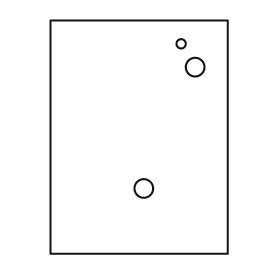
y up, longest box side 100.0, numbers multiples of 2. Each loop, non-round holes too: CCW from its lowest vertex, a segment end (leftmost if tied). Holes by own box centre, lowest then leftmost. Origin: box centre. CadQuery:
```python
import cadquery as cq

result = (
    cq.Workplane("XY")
    .moveTo(-38.0, -50.0)
    .lineTo(38.0, -50.0)
    .lineTo(38.0, 50.0)
    .lineTo(-38.0, 50.0)
    .close()
    .moveTo(2.0, -22.0)
    .circle(4.0)
    .moveTo(24.0, 30.0)
    .circle(4.0)
    .moveTo(18.0, 40.0)
    .circle(2.0)
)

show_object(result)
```